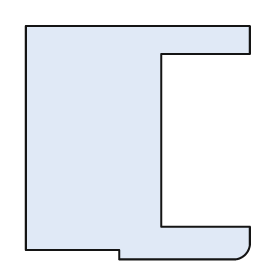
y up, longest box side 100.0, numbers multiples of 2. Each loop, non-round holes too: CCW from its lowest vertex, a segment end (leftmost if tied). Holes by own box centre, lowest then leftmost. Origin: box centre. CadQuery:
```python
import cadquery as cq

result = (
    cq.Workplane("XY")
    .moveTo(-8.0, -50.0)
    .lineTo(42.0, -50.0)
    .threePointArc((46.0, -48.0), (48.0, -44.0))
    .lineTo(48.0, -36.0)
    .lineTo(10.0, -36.0)
    .lineTo(10.0, 38.0)
    .lineTo(48.0, 38.0)
    .lineTo(48.0, 50.0)
    .lineTo(-48.0, 50.0)
    .lineTo(-48.0, -46.0)
    .lineTo(-8.0, -46.0)
    .close()
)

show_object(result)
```